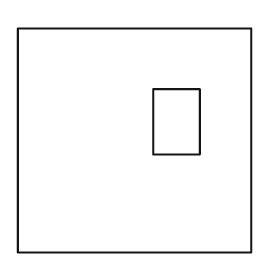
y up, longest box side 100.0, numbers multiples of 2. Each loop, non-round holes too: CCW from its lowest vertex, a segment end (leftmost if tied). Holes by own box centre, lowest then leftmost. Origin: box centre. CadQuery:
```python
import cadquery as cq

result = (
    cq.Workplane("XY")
    .moveTo(-50.0, -48.0)
    .lineTo(50.0, -48.0)
    .lineTo(50.0, 48.0)
    .lineTo(-50.0, 48.0)
    .close()
    .moveTo(8.0, -6.0)
    .lineTo(28.0, -6.0)
    .lineTo(28.0, 22.0)
    .lineTo(8.0, 22.0)
    .close()
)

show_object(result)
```